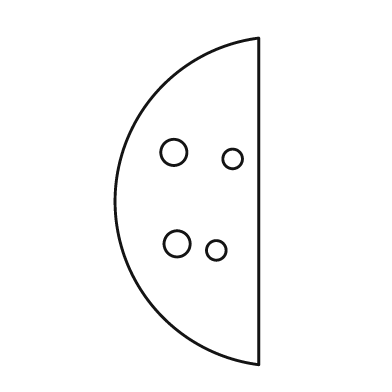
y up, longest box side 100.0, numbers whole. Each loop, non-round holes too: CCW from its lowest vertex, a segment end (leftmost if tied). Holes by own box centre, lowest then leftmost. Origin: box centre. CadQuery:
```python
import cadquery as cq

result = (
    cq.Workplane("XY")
    .moveTo(22.0, -50.0)
    .lineTo(22.0, 50.0)
    .threePointArc((-22.0, 0.0), (22.0, -50.0))
    .close()
    .moveTo(9.0, -15.0)
    .circle(3.0)
    .moveTo(-3.0, -13.0)
    .circle(4.0)
    .moveTo(14.0, 13.0)
    .circle(3.0)
    .moveTo(-4.0, 15.0)
    .circle(4.0)
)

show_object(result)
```